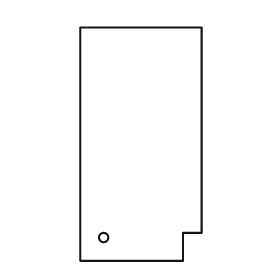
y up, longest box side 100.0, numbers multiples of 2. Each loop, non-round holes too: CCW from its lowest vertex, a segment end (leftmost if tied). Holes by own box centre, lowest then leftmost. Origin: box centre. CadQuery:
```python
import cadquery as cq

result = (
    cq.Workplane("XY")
    .moveTo(-26.0, -50.0)
    .lineTo(18.0, -50.0)
    .lineTo(18.0, -38.0)
    .lineTo(26.0, -38.0)
    .lineTo(26.0, 50.0)
    .lineTo(-26.0, 50.0)
    .close()
    .moveTo(-16.0, -40.0)
    .circle(2.0)
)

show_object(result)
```